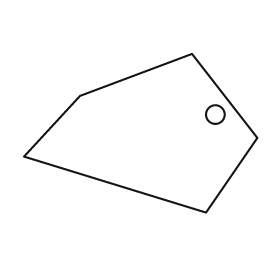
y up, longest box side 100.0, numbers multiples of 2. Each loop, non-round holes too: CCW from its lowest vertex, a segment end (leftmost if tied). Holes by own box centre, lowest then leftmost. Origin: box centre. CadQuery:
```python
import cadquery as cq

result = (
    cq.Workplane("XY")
    .moveTo(28.0, -34.0)
    .lineTo(50.0, -2.0)
    .lineTo(22.0, 34.0)
    .lineTo(-26.0, 16.0)
    .lineTo(-50.0, -10.0)
    .close()
    .moveTo(32.0, 8.0)
    .circle(4.0)
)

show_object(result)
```